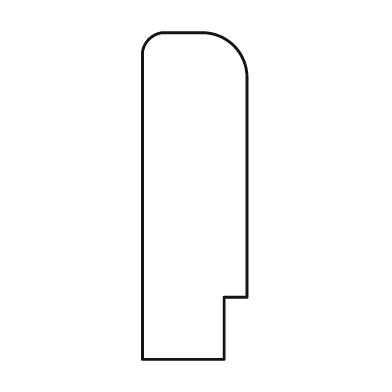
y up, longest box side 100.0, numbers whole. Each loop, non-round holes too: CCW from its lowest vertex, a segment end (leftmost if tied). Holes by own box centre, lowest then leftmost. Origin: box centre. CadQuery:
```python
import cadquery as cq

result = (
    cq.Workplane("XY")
    .moveTo(-16.0, -50.0)
    .lineTo(9.0, -50.0)
    .lineTo(9.0, -31.0)
    .lineTo(16.0, -31.0)
    .lineTo(16.0, 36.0)
    .threePointArc((12.0, 46.0), (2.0, 50.0))
    .lineTo(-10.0, 50.0)
    .threePointArc((-14.0, 48.0), (-16.0, 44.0))
    .close()
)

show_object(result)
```